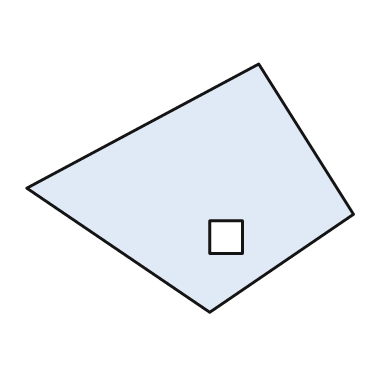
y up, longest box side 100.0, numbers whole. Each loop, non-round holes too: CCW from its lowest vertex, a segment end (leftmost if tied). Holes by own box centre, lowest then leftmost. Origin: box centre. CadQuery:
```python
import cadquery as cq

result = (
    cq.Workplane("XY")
    .moveTo(6.0, -38.0)
    .lineTo(50.0, -8.0)
    .lineTo(21.0, 38.0)
    .lineTo(-50.0, 0.0)
    .close()
    .moveTo(6.0, -20.0)
    .lineTo(16.0, -20.0)
    .lineTo(16.0, -10.0)
    .lineTo(6.0, -10.0)
    .close()
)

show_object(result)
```